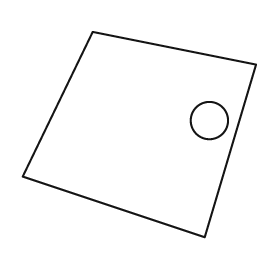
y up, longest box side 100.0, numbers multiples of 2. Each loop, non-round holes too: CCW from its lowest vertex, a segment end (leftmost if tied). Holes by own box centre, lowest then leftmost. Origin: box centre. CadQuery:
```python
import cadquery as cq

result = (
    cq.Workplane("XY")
    .moveTo(28.0, -44.0)
    .lineTo(50.0, 30.0)
    .lineTo(-20.0, 44.0)
    .lineTo(-50.0, -18.0)
    .close()
    .moveTo(30.0, 6.0)
    .circle(8.0)
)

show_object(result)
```